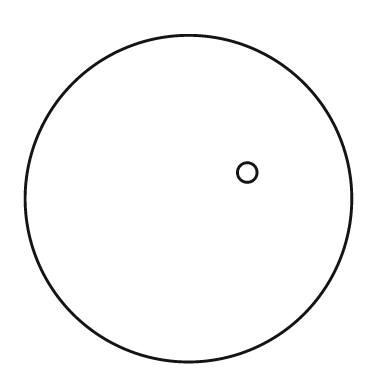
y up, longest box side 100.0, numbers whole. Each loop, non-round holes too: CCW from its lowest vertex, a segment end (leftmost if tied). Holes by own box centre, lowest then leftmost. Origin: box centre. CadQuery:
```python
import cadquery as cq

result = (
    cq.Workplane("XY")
    .moveTo(0.0, 0.0)
    .circle(50.0)
    .moveTo(18.0, 8.0)
    .circle(3.0)
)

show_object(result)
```